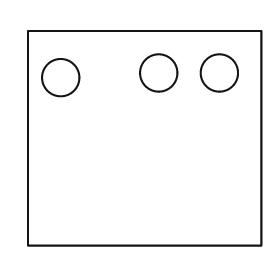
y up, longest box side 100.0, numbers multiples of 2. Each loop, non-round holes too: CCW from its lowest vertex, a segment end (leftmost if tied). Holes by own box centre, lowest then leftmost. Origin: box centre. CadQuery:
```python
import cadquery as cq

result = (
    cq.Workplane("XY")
    .moveTo(-50.0, -46.0)
    .lineTo(50.0, -46.0)
    .lineTo(50.0, 46.0)
    .lineTo(-50.0, 46.0)
    .close()
    .moveTo(-36.0, 26.0)
    .circle(8.0)
    .moveTo(6.0, 28.0)
    .circle(8.0)
    .moveTo(32.0, 28.0)
    .circle(8.0)
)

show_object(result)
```